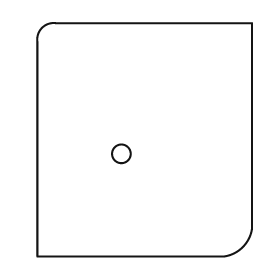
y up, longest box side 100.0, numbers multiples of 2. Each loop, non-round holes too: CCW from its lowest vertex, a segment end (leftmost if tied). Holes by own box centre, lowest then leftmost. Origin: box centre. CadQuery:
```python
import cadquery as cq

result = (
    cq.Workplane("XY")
    .moveTo(-46.0, -50.0)
    .lineTo(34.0, -50.0)
    .threePointArc((42.0, -46.0), (46.0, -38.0))
    .lineTo(46.0, 50.0)
    .lineTo(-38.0, 50.0)
    .threePointArc((-44.0, 48.0), (-46.0, 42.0))
    .close()
    .moveTo(-10.0, -6.0)
    .circle(4.0)
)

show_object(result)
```